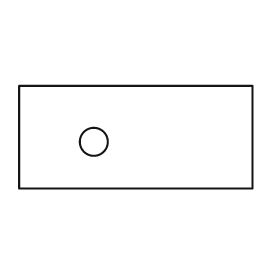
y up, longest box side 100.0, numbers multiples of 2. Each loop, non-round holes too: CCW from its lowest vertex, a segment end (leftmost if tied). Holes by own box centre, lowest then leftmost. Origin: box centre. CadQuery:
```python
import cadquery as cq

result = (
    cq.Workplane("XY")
    .moveTo(-50.0, -22.0)
    .lineTo(50.0, -22.0)
    .lineTo(50.0, 22.0)
    .lineTo(-50.0, 22.0)
    .close()
    .moveTo(-18.0, -2.0)
    .circle(6.0)
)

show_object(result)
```